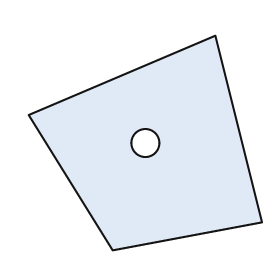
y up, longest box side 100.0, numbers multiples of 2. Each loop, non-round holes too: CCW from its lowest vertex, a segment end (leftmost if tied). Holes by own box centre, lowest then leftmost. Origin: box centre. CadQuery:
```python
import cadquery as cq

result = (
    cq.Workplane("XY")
    .moveTo(-14.0, -46.0)
    .lineTo(50.0, -34.0)
    .lineTo(30.0, 46.0)
    .lineTo(-50.0, 12.0)
    .close()
    .moveTo(0.0, 0.0)
    .circle(6.0)
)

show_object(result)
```